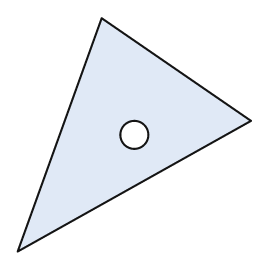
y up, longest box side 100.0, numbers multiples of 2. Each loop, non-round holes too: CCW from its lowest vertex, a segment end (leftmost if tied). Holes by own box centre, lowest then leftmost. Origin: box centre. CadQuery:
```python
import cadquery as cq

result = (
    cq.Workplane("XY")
    .moveTo(-50.0, -50.0)
    .lineTo(50.0, 6.0)
    .lineTo(-14.0, 50.0)
    .close()
    .moveTo(0.0, 0.0)
    .circle(6.0)
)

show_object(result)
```